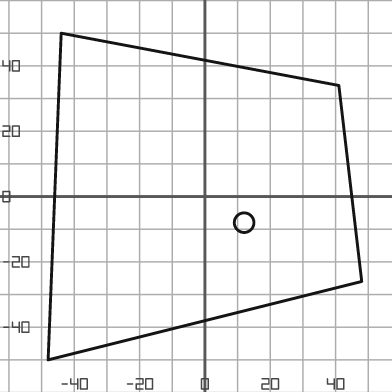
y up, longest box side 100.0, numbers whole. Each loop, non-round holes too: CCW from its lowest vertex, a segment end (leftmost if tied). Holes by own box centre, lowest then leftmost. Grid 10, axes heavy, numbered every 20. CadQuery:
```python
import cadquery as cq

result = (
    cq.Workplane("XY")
    .moveTo(-48.0, -50.0)
    .lineTo(48.0, -26.0)
    .lineTo(41.0, 34.0)
    .lineTo(-44.0, 50.0)
    .close()
    .moveTo(12.0, -8.0)
    .circle(3.0)
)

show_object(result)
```